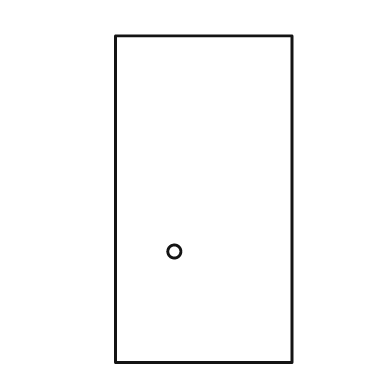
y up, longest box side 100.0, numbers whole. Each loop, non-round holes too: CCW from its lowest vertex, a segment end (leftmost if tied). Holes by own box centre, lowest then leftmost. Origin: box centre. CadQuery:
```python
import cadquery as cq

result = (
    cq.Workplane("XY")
    .moveTo(-27.0, -50.0)
    .lineTo(27.0, -50.0)
    .lineTo(27.0, 50.0)
    .lineTo(-27.0, 50.0)
    .close()
    .moveTo(-9.0, -16.0)
    .circle(2.0)
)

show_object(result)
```